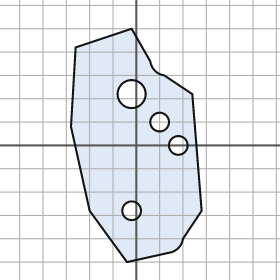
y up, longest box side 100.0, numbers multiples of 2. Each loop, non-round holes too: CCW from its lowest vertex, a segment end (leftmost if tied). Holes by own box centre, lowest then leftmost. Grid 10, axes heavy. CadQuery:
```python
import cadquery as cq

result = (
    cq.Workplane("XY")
    .moveTo(-4.0, -50.0)
    .lineTo(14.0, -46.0)
    .threePointArc((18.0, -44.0), (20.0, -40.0))
    .lineTo(28.0, -28.0)
    .lineTo(24.0, 22.0)
    .lineTo(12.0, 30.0)
    .threePointArc((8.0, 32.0), (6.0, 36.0))
    .lineTo(-2.0, 50.0)
    .lineTo(-26.0, 42.0)
    .lineTo(-28.0, 8.0)
    .lineTo(-20.0, -28.0)
    .close()
    .moveTo(-2.0, -28.0)
    .circle(4.0)
    .moveTo(18.0, 0.0)
    .circle(4.0)
    .moveTo(10.0, 10.0)
    .circle(4.0)
    .moveTo(-2.0, 22.0)
    .circle(6.0)
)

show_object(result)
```